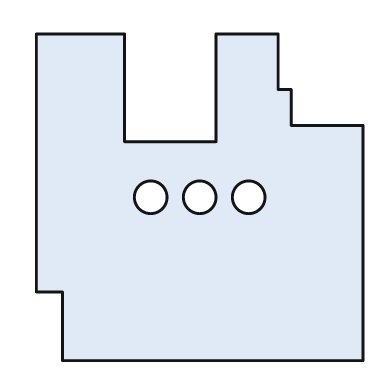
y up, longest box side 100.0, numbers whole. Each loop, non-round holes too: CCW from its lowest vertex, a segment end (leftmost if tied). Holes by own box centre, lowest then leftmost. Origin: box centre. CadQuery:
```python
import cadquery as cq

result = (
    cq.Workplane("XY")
    .moveTo(-42.0, -50.0)
    .lineTo(50.0, -50.0)
    .lineTo(50.0, 22.0)
    .lineTo(28.0, 22.0)
    .lineTo(28.0, 33.0)
    .lineTo(24.0, 33.0)
    .lineTo(24.0, 50.0)
    .lineTo(5.0, 50.0)
    .lineTo(5.0, 17.0)
    .lineTo(-23.0, 17.0)
    .lineTo(-23.0, 50.0)
    .lineTo(-50.0, 50.0)
    .lineTo(-50.0, -29.0)
    .lineTo(-42.0, -29.0)
    .close()
    .moveTo(-15.0, 0.0)
    .circle(5.0)
    .moveTo(0.0, 0.0)
    .circle(5.0)
    .moveTo(15.0, 0.0)
    .circle(5.0)
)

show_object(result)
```